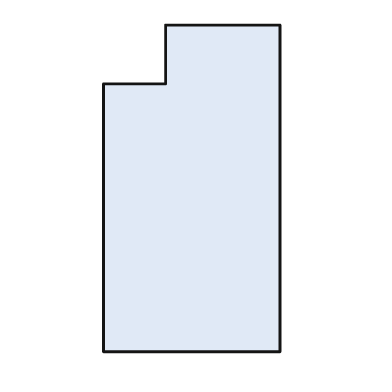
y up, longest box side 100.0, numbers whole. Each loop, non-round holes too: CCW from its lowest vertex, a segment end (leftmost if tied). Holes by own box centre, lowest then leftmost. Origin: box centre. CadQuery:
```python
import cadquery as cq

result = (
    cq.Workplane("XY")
    .moveTo(-27.0, -50.0)
    .lineTo(27.0, -50.0)
    .lineTo(27.0, 50.0)
    .lineTo(-8.0, 50.0)
    .lineTo(-8.0, 32.0)
    .lineTo(-27.0, 32.0)
    .close()
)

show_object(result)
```